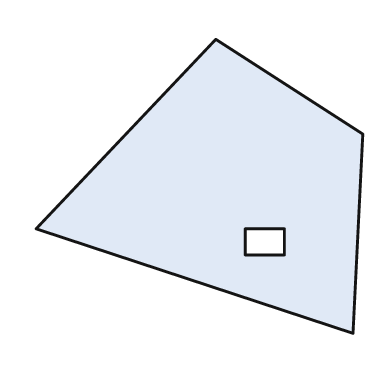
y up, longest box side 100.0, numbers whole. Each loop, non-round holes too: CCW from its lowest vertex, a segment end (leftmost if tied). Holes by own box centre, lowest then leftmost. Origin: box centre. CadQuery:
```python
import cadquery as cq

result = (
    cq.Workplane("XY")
    .moveTo(47.0, -45.0)
    .lineTo(50.0, 16.0)
    .lineTo(5.0, 45.0)
    .lineTo(-50.0, -13.0)
    .close()
    .moveTo(14.0, -21.0)
    .lineTo(26.0, -21.0)
    .lineTo(26.0, -13.0)
    .lineTo(14.0, -13.0)
    .close()
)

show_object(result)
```